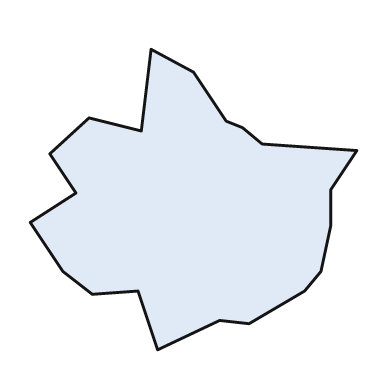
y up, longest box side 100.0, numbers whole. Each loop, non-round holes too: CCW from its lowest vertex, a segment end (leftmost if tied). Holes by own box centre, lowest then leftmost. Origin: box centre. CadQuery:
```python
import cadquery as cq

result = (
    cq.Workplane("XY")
    .moveTo(-11.0, -46.0)
    .lineTo(8.0, -37.0)
    .lineTo(17.0, -38.0)
    .lineTo(34.0, -28.0)
    .lineTo(39.0, -22.0)
    .lineTo(42.0, -8.0)
    .lineTo(42.0, 3.0)
    .lineTo(50.0, 15.0)
    .lineTo(21.0, 17.0)
    .lineTo(15.0, 22.0)
    .lineTo(10.0, 24.0)
    .lineTo(0.0, 39.0)
    .lineTo(-13.0, 46.0)
    .lineTo(-16.0, 21.0)
    .lineTo(-32.0, 25.0)
    .lineTo(-44.0, 14.0)
    .lineTo(-36.0, 2.0)
    .lineTo(-50.0, -7.0)
    .lineTo(-40.0, -22.0)
    .lineTo(-31.0, -29.0)
    .lineTo(-17.0, -28.0)
    .close()
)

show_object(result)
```